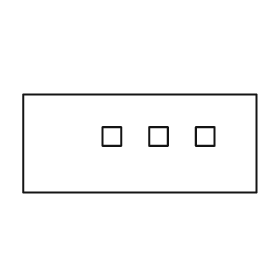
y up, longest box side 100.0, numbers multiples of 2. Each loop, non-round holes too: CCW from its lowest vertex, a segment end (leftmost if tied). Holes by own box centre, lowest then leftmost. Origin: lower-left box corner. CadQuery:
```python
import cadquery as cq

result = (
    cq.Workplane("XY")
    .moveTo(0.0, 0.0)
    .lineTo(100.0, 0.0)
    .lineTo(100.0, 42.0)
    .lineTo(0.0, 42.0)
    .close()
    .moveTo(34.0, 20.0)
    .lineTo(42.0, 20.0)
    .lineTo(42.0, 28.0)
    .lineTo(34.0, 28.0)
    .close()
    .moveTo(54.0, 20.0)
    .lineTo(62.0, 20.0)
    .lineTo(62.0, 28.0)
    .lineTo(54.0, 28.0)
    .close()
    .moveTo(74.0, 20.0)
    .lineTo(82.0, 20.0)
    .lineTo(82.0, 28.0)
    .lineTo(74.0, 28.0)
    .close()
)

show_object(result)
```